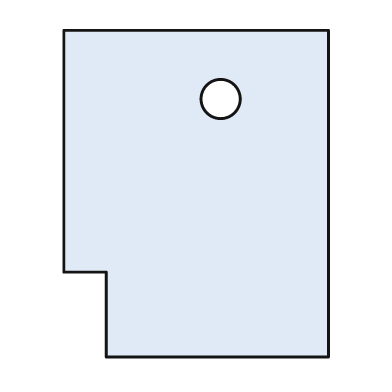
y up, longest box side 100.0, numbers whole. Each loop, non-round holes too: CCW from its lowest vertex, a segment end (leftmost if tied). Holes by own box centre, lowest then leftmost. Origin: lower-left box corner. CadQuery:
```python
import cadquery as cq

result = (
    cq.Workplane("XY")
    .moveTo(13.0, 0.0)
    .lineTo(81.0, 0.0)
    .lineTo(81.0, 100.0)
    .lineTo(0.0, 100.0)
    .lineTo(0.0, 26.0)
    .lineTo(13.0, 26.0)
    .close()
    .moveTo(48.0, 79.0)
    .circle(6.0)
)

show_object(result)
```